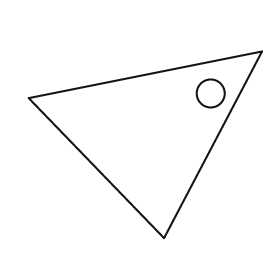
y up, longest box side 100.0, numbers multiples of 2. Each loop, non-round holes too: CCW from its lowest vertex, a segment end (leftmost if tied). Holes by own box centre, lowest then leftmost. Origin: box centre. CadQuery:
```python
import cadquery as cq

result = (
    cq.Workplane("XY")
    .moveTo(8.0, -40.0)
    .lineTo(50.0, 40.0)
    .lineTo(-50.0, 20.0)
    .close()
    .moveTo(28.0, 22.0)
    .circle(6.0)
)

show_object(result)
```